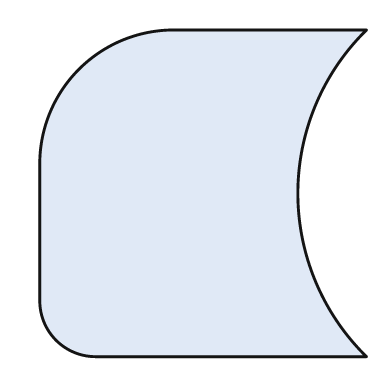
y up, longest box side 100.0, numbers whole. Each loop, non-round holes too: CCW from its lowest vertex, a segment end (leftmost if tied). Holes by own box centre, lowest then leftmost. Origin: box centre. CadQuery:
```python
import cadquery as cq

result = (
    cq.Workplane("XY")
    .moveTo(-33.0, -50.0)
    .lineTo(50.0, -50.0)
    .threePointArc((29.0, 0.0), (50.0, 50.0))
    .lineTo(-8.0, 50.0)
    .threePointArc((-38.0, 38.0), (-50.0, 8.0))
    .lineTo(-50.0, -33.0)
    .threePointArc((-45.0, -45.0), (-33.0, -50.0))
    .close()
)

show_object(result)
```